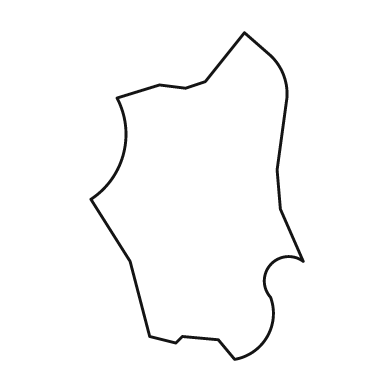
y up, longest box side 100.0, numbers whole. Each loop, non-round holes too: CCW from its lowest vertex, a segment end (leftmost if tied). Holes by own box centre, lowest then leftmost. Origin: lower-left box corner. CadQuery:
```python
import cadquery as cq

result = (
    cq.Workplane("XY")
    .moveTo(44.0, 0.0)
    .threePointArc((54.0, 7.0), (55.0, 19.0))
    .threePointArc((55.0, 29.0), (65.0, 30.0))
    .lineTo(58.0, 46.0)
    .lineTo(57.0, 58.0)
    .lineTo(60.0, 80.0)
    .threePointArc((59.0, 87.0), (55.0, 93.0))
    .lineTo(47.0, 100.0)
    .lineTo(35.0, 85.0)
    .lineTo(29.0, 83.0)
    .lineTo(21.0, 84.0)
    .lineTo(8.0, 80.0)
    .threePointArc((10.0, 63.0), (0.0, 49.0))
    .lineTo(12.0, 30.0)
    .lineTo(18.0, 7.0)
    .lineTo(26.0, 5.0)
    .lineTo(28.0, 7.0)
    .lineTo(39.0, 6.0)
    .close()
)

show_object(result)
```